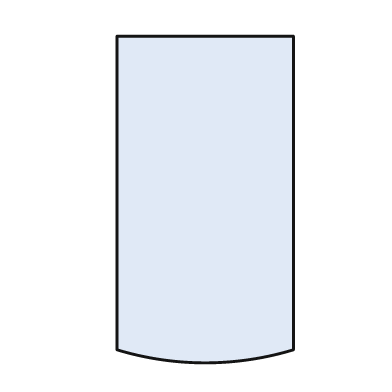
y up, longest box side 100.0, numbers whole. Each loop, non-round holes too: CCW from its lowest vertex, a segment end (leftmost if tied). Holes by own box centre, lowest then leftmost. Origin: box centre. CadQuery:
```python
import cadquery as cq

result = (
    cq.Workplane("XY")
    .moveTo(-27.0, -46.0)
    .threePointArc((0.0, -50.0), (27.0, -46.0))
    .lineTo(27.0, 50.0)
    .lineTo(-27.0, 50.0)
    .close()
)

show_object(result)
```